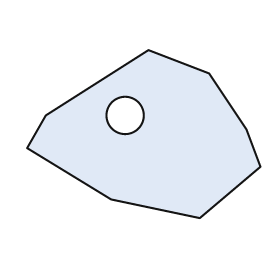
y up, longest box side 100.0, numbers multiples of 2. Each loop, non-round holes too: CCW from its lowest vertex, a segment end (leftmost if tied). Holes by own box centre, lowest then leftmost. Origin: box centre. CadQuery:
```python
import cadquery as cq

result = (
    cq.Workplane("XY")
    .moveTo(24.0, -36.0)
    .lineTo(50.0, -14.0)
    .lineTo(44.0, 2.0)
    .lineTo(28.0, 26.0)
    .lineTo(2.0, 36.0)
    .lineTo(-42.0, 8.0)
    .lineTo(-50.0, -6.0)
    .lineTo(-14.0, -28.0)
    .close()
    .moveTo(-8.0, 8.0)
    .circle(8.0)
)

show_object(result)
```